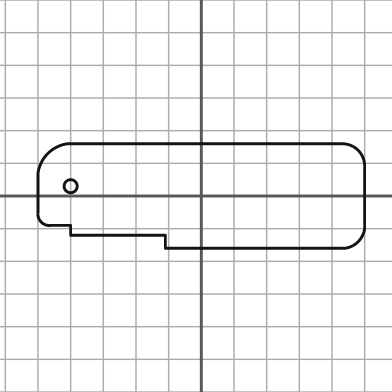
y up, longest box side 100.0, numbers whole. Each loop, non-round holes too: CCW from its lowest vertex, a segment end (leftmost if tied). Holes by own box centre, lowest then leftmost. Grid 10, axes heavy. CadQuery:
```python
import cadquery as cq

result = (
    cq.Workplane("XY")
    .moveTo(-11.0, -16.0)
    .lineTo(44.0, -16.0)
    .threePointArc((48.0, -14.0), (50.0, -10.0))
    .lineTo(50.0, 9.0)
    .threePointArc((48.0, 14.0), (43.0, 16.0))
    .lineTo(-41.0, 16.0)
    .threePointArc((-47.0, 13.0), (-50.0, 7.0))
    .lineTo(-50.0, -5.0)
    .threePointArc((-49.0, -8.0), (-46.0, -9.0))
    .lineTo(-40.0, -9.0)
    .lineTo(-40.0, -12.0)
    .lineTo(-11.0, -12.0)
    .close()
    .moveTo(-40.0, 3.0)
    .circle(2.0)
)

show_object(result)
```